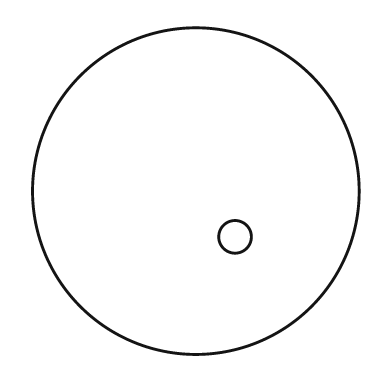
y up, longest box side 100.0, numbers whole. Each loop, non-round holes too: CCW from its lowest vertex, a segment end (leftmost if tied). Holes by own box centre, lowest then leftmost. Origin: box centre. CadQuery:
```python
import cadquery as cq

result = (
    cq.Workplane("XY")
    .moveTo(0.0, 0.0)
    .circle(50.0)
    .moveTo(12.0, -14.0)
    .circle(5.0)
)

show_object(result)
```